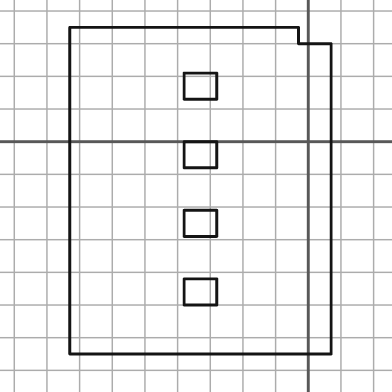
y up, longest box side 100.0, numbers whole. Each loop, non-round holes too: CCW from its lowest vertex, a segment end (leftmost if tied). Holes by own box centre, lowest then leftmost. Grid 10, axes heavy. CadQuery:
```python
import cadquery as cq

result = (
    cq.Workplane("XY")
    .moveTo(-73.0, -65.0)
    .lineTo(7.0, -65.0)
    .lineTo(7.0, 30.0)
    .lineTo(-3.0, 30.0)
    .lineTo(-3.0, 35.0)
    .lineTo(-73.0, 35.0)
    .close()
    .moveTo(-38.0, -50.0)
    .lineTo(-28.0, -50.0)
    .lineTo(-28.0, -42.0)
    .lineTo(-38.0, -42.0)
    .close()
    .moveTo(-38.0, -29.0)
    .lineTo(-28.0, -29.0)
    .lineTo(-28.0, -21.0)
    .lineTo(-38.0, -21.0)
    .close()
    .moveTo(-38.0, -8.0)
    .lineTo(-28.0, -8.0)
    .lineTo(-28.0, 0.0)
    .lineTo(-38.0, 0.0)
    .close()
    .moveTo(-38.0, 13.0)
    .lineTo(-28.0, 13.0)
    .lineTo(-28.0, 21.0)
    .lineTo(-38.0, 21.0)
    .close()
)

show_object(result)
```